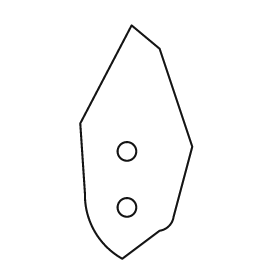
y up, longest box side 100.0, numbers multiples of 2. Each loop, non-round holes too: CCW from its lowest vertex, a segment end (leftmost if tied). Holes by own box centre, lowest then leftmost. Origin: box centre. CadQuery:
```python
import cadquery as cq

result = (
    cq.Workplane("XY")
    .moveTo(-6.0, -50.0)
    .lineTo(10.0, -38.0)
    .threePointArc((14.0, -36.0), (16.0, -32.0))
    .lineTo(24.0, -2.0)
    .lineTo(10.0, 40.0)
    .lineTo(-2.0, 50.0)
    .lineTo(-24.0, 8.0)
    .lineTo(-22.0, -22.0)
    .threePointArc((-18.0, -38.0), (-6.0, -50.0))
    .close()
    .moveTo(-4.0, -28.0)
    .circle(4.0)
    .moveTo(-4.0, -4.0)
    .circle(4.0)
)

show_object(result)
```